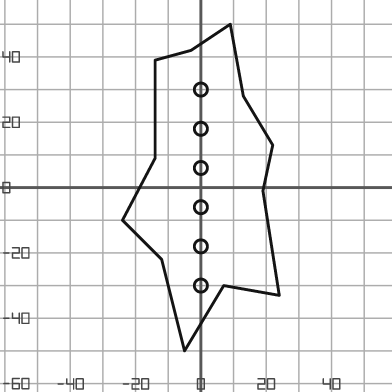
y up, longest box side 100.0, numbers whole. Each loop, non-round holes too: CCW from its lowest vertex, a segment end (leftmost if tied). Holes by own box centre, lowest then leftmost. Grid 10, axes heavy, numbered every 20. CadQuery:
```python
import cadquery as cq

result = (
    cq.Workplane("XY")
    .moveTo(-5.0, -50.0)
    .lineTo(7.0, -30.0)
    .lineTo(24.0, -33.0)
    .lineTo(19.0, -1.0)
    .lineTo(22.0, 13.0)
    .lineTo(13.0, 28.0)
    .lineTo(9.0, 50.0)
    .lineTo(-3.0, 42.0)
    .lineTo(-14.0, 39.0)
    .lineTo(-14.0, 9.0)
    .lineTo(-24.0, -10.0)
    .lineTo(-12.0, -22.0)
    .close()
    .moveTo(0.0, -30.0)
    .circle(2.0)
    .moveTo(0.0, -18.0)
    .circle(2.0)
    .moveTo(0.0, -6.0)
    .circle(2.0)
    .moveTo(0.0, 6.0)
    .circle(2.0)
    .moveTo(0.0, 18.0)
    .circle(2.0)
    .moveTo(0.0, 30.0)
    .circle(2.0)
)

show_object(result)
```